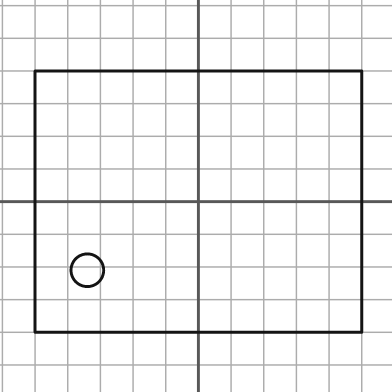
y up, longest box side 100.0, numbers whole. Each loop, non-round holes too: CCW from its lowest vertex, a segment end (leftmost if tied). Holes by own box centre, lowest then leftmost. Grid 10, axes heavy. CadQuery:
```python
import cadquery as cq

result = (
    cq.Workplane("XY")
    .moveTo(-50.0, -40.0)
    .lineTo(50.0, -40.0)
    .lineTo(50.0, 40.0)
    .lineTo(-50.0, 40.0)
    .close()
    .moveTo(-34.0, -21.0)
    .circle(5.0)
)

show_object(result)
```